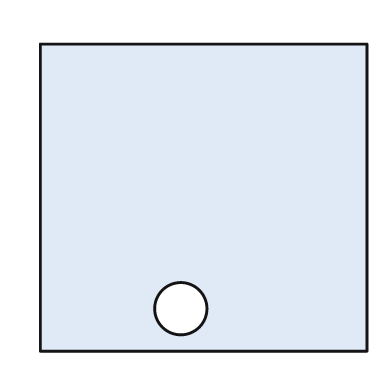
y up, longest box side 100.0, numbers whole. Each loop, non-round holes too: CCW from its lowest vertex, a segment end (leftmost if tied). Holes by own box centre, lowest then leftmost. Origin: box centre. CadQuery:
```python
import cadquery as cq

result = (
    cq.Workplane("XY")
    .moveTo(-50.0, -47.0)
    .lineTo(50.0, -47.0)
    .lineTo(50.0, 47.0)
    .lineTo(-50.0, 47.0)
    .close()
    .moveTo(-7.0, -34.0)
    .circle(8.0)
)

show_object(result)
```